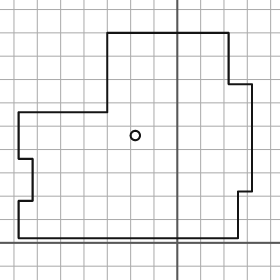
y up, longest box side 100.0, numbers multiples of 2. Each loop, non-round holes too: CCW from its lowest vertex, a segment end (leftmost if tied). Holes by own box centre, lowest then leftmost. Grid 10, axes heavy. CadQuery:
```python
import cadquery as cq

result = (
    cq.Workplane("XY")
    .moveTo(-68.0, 2.0)
    .lineTo(26.0, 2.0)
    .lineTo(26.0, 22.0)
    .lineTo(32.0, 22.0)
    .lineTo(32.0, 68.0)
    .lineTo(22.0, 68.0)
    .lineTo(22.0, 90.0)
    .lineTo(-30.0, 90.0)
    .lineTo(-30.0, 56.0)
    .lineTo(-68.0, 56.0)
    .lineTo(-68.0, 36.0)
    .lineTo(-62.0, 36.0)
    .lineTo(-62.0, 18.0)
    .lineTo(-68.0, 18.0)
    .close()
    .moveTo(-18.0, 46.0)
    .circle(2.0)
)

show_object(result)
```